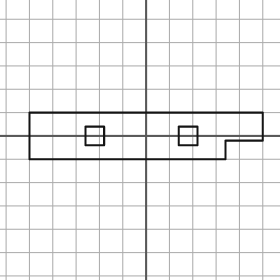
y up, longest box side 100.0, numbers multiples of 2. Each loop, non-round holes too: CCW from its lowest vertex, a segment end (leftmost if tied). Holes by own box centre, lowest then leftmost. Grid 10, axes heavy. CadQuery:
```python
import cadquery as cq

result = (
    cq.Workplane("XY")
    .moveTo(-50.0, -10.0)
    .lineTo(34.0, -10.0)
    .lineTo(34.0, -2.0)
    .lineTo(50.0, -2.0)
    .lineTo(50.0, 10.0)
    .lineTo(-50.0, 10.0)
    .close()
    .moveTo(-26.0, -4.0)
    .lineTo(-18.0, -4.0)
    .lineTo(-18.0, 4.0)
    .lineTo(-26.0, 4.0)
    .close()
    .moveTo(14.0, -4.0)
    .lineTo(22.0, -4.0)
    .lineTo(22.0, 4.0)
    .lineTo(14.0, 4.0)
    .close()
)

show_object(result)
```